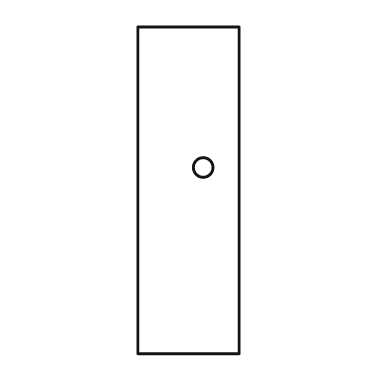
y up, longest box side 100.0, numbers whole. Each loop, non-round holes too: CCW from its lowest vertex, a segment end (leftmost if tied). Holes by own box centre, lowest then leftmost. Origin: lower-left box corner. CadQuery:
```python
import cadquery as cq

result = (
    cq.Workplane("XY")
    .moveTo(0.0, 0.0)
    .lineTo(31.0, 0.0)
    .lineTo(31.0, 100.0)
    .lineTo(0.0, 100.0)
    .close()
    .moveTo(20.0, 57.0)
    .circle(3.0)
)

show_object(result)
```